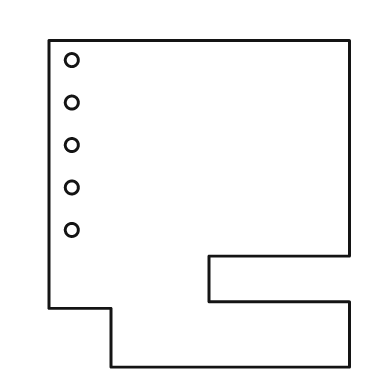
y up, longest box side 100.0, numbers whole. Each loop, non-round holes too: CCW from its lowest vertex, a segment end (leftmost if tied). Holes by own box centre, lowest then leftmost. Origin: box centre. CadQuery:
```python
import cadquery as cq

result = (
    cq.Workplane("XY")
    .moveTo(-27.0, -50.0)
    .lineTo(46.0, -50.0)
    .lineTo(46.0, -30.0)
    .lineTo(3.0, -30.0)
    .lineTo(3.0, -16.0)
    .lineTo(46.0, -16.0)
    .lineTo(46.0, 50.0)
    .lineTo(-46.0, 50.0)
    .lineTo(-46.0, -32.0)
    .lineTo(-27.0, -32.0)
    .close()
    .moveTo(-39.0, -8.0)
    .circle(2.0)
    .moveTo(-39.0, 5.0)
    .circle(2.0)
    .moveTo(-39.0, 18.0)
    .circle(2.0)
    .moveTo(-39.0, 31.0)
    .circle(2.0)
    .moveTo(-39.0, 44.0)
    .circle(2.0)
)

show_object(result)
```